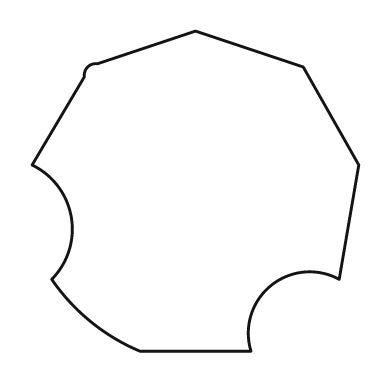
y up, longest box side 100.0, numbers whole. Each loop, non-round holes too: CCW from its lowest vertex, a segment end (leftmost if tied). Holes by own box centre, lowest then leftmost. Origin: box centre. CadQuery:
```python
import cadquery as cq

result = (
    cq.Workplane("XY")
    .moveTo(-17.0, -49.0)
    .lineTo(17.0, -49.0)
    .threePointArc((23.0, -29.0), (44.0, -27.0))
    .lineTo(50.0, 8.0)
    .lineTo(33.0, 38.0)
    .lineTo(0.0, 49.0)
    .lineTo(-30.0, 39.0)
    .threePointArc((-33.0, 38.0), (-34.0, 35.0))
    .lineTo(-50.0, 8.0)
    .threePointArc((-38.0, -8.0), (-44.0, -27.0))
    .threePointArc((-32.0, -40.0), (-17.0, -49.0))
    .close()
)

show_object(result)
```